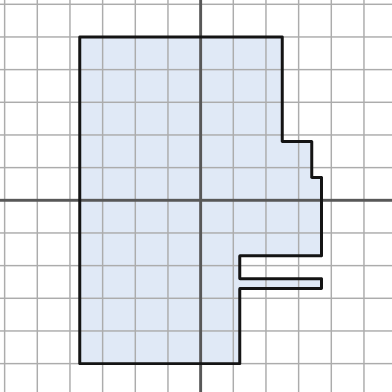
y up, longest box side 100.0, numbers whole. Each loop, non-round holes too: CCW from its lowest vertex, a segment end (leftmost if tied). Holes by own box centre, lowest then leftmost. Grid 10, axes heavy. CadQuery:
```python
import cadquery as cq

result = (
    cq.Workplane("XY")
    .moveTo(-37.0, -50.0)
    .lineTo(12.0, -50.0)
    .lineTo(12.0, -27.0)
    .lineTo(37.0, -27.0)
    .lineTo(37.0, -24.0)
    .lineTo(12.0, -24.0)
    .lineTo(12.0, -17.0)
    .lineTo(37.0, -17.0)
    .lineTo(37.0, 7.0)
    .lineTo(34.0, 7.0)
    .lineTo(34.0, 18.0)
    .lineTo(25.0, 18.0)
    .lineTo(25.0, 50.0)
    .lineTo(-37.0, 50.0)
    .close()
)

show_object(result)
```